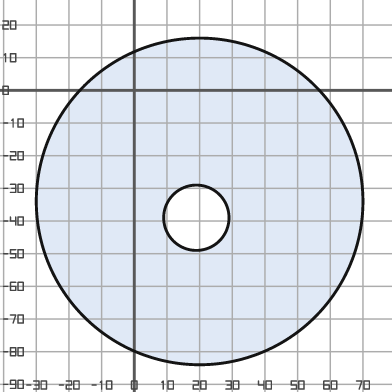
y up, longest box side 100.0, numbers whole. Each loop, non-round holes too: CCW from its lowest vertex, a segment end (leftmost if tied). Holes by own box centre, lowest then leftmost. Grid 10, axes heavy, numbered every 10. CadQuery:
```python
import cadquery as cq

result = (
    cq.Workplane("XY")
    .moveTo(20.0, -34.0)
    .circle(50.0)
    .moveTo(19.0, -39.0)
    .circle(10.0)
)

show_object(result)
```